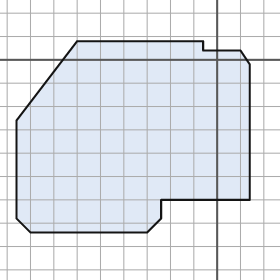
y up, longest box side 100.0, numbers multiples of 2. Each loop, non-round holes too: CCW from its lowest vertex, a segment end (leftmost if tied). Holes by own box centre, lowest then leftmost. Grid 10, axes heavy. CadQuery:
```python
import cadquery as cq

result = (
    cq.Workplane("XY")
    .moveTo(-80.0, -74.0)
    .lineTo(-30.0, -74.0)
    .lineTo(-24.0, -68.0)
    .lineTo(-24.0, -60.0)
    .lineTo(14.0, -60.0)
    .lineTo(14.0, -2.0)
    .lineTo(10.0, 4.0)
    .lineTo(-6.0, 4.0)
    .lineTo(-6.0, 8.0)
    .lineTo(-60.0, 8.0)
    .lineTo(-86.0, -26.0)
    .lineTo(-86.0, -68.0)
    .close()
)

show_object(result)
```